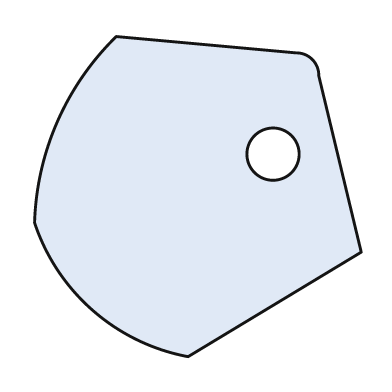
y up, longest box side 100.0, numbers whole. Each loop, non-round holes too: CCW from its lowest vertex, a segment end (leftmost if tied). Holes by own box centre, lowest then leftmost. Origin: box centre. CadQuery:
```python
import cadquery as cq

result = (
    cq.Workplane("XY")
    .moveTo(-3.0, -49.0)
    .lineTo(50.0, -17.0)
    .lineTo(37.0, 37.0)
    .threePointArc((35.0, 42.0), (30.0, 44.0))
    .lineTo(-25.0, 49.0)
    .threePointArc((-43.0, 23.0), (-50.0, -8.0))
    .threePointArc((-32.0, -35.0), (-3.0, -49.0))
    .close()
    .moveTo(23.0, 13.0)
    .circle(8.0)
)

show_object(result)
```